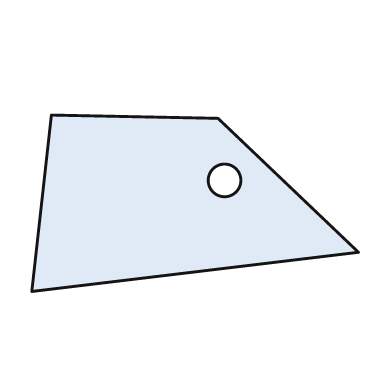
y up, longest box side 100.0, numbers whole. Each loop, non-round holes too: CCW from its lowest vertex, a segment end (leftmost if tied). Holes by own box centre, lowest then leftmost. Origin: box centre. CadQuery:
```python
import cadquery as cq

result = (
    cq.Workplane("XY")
    .moveTo(-50.0, -27.0)
    .lineTo(50.0, -15.0)
    .lineTo(7.0, 26.0)
    .lineTo(-44.0, 27.0)
    .close()
    .moveTo(9.0, 7.0)
    .circle(5.0)
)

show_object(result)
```